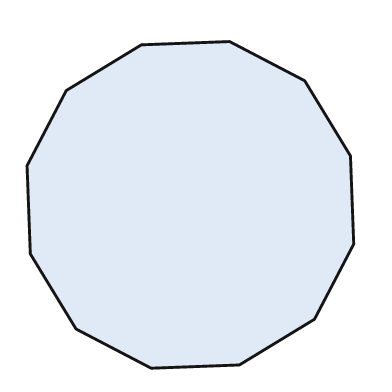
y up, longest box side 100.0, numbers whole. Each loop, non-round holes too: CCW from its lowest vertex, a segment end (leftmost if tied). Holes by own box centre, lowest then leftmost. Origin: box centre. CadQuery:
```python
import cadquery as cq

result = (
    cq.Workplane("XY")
    .moveTo(-12.0, -50.0)
    .lineTo(15.0, -49.0)
    .lineTo(38.0, -35.0)
    .lineTo(50.0, -12.0)
    .lineTo(49.0, 15.0)
    .lineTo(35.0, 38.0)
    .lineTo(12.0, 50.0)
    .lineTo(-15.0, 49.0)
    .lineTo(-38.0, 35.0)
    .lineTo(-50.0, 12.0)
    .lineTo(-49.0, -15.0)
    .lineTo(-35.0, -38.0)
    .close()
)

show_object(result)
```